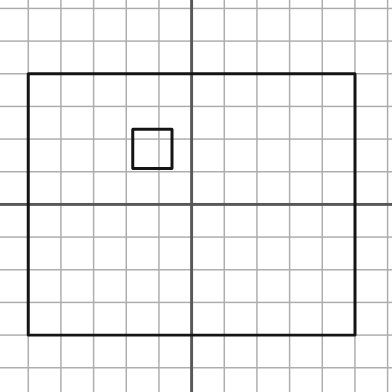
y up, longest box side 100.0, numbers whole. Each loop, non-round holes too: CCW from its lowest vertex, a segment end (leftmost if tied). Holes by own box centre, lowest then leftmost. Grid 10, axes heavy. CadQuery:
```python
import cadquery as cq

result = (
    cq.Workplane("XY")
    .moveTo(-50.0, -40.0)
    .lineTo(50.0, -40.0)
    .lineTo(50.0, 40.0)
    .lineTo(-50.0, 40.0)
    .close()
    .moveTo(-18.0, 11.0)
    .lineTo(-6.0, 11.0)
    .lineTo(-6.0, 23.0)
    .lineTo(-18.0, 23.0)
    .close()
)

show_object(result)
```